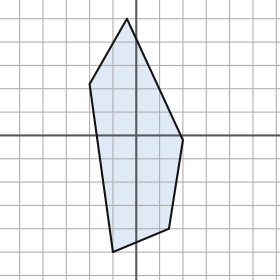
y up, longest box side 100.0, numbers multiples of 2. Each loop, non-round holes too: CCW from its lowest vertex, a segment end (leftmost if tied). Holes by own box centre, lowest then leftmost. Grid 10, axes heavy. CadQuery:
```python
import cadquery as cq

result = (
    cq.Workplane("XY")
    .moveTo(-10.0, -50.0)
    .lineTo(14.0, -40.0)
    .lineTo(20.0, -2.0)
    .lineTo(-4.0, 50.0)
    .lineTo(-20.0, 22.0)
    .close()
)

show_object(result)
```